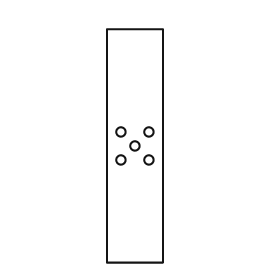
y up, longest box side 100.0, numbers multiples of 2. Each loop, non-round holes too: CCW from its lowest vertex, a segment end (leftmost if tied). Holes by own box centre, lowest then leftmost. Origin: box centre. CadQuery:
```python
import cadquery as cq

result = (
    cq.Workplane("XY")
    .moveTo(-12.0, -50.0)
    .lineTo(12.0, -50.0)
    .lineTo(12.0, 50.0)
    .lineTo(-12.0, 50.0)
    .close()
    .moveTo(-6.0, -6.0)
    .circle(2.0)
    .moveTo(6.0, -6.0)
    .circle(2.0)
    .moveTo(0.0, 0.0)
    .circle(2.0)
    .moveTo(-6.0, 6.0)
    .circle(2.0)
    .moveTo(6.0, 6.0)
    .circle(2.0)
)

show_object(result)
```